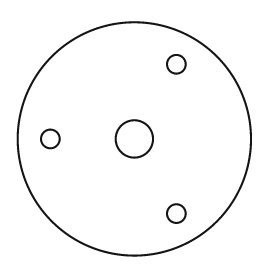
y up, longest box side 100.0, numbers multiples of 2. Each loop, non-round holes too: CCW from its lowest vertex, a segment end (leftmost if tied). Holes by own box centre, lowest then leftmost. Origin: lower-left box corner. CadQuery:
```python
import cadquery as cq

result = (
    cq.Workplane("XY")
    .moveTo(50.0, 50.0)
    .circle(50.0)
    .moveTo(68.0, 18.0)
    .circle(4.0)
    .moveTo(14.0, 50.0)
    .circle(4.0)
    .moveTo(50.0, 50.0)
    .circle(8.0)
    .moveTo(68.0, 82.0)
    .circle(4.0)
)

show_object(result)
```